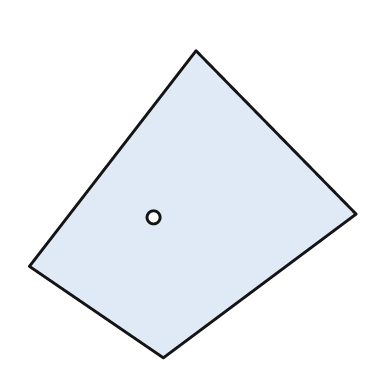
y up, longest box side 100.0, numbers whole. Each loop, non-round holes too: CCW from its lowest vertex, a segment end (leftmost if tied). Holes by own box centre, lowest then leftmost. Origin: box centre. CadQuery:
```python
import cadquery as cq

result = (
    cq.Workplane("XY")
    .moveTo(-9.0, -47.0)
    .lineTo(50.0, -3.0)
    .lineTo(1.0, 47.0)
    .lineTo(-50.0, -19.0)
    .close()
    .moveTo(-12.0, -4.0)
    .circle(2.0)
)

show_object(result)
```